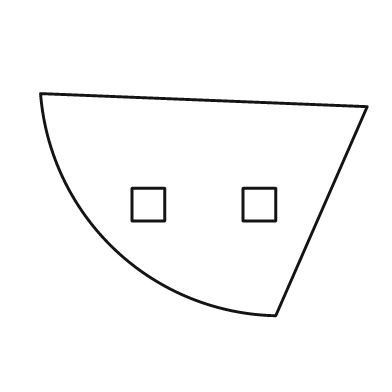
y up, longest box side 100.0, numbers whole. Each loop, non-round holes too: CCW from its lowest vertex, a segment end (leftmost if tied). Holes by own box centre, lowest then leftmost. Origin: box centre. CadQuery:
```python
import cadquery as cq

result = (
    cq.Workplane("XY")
    .moveTo(22.0, -34.0)
    .lineTo(50.0, 30.0)
    .lineTo(-50.0, 34.0)
    .threePointArc((-27.0, -14.0), (22.0, -34.0))
    .close()
    .moveTo(-22.0, -5.0)
    .lineTo(-12.0, -5.0)
    .lineTo(-12.0, 5.0)
    .lineTo(-22.0, 5.0)
    .close()
    .moveTo(12.0, -5.0)
    .lineTo(22.0, -5.0)
    .lineTo(22.0, 5.0)
    .lineTo(12.0, 5.0)
    .close()
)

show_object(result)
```